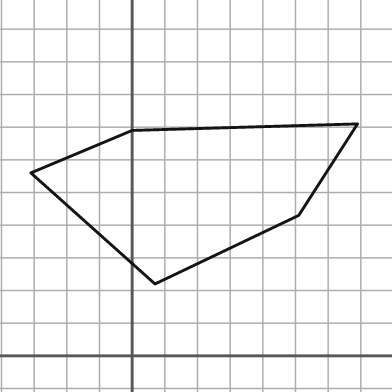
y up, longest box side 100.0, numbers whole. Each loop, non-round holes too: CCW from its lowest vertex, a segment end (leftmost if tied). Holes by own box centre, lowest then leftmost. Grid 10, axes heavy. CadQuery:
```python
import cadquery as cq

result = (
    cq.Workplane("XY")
    .moveTo(7.0, 22.0)
    .lineTo(51.0, 43.0)
    .lineTo(69.0, 71.0)
    .lineTo(0.0, 69.0)
    .lineTo(-31.0, 56.0)
    .close()
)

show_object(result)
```